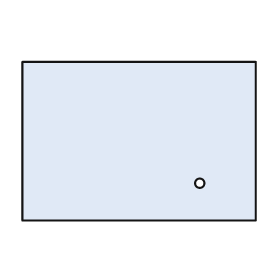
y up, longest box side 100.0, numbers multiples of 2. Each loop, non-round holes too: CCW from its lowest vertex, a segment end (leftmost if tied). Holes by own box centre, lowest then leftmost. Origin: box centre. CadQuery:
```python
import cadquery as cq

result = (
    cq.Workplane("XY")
    .moveTo(-50.0, -34.0)
    .lineTo(50.0, -34.0)
    .lineTo(50.0, 34.0)
    .lineTo(-50.0, 34.0)
    .close()
    .moveTo(26.0, -18.0)
    .circle(2.0)
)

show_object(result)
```